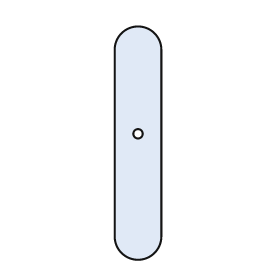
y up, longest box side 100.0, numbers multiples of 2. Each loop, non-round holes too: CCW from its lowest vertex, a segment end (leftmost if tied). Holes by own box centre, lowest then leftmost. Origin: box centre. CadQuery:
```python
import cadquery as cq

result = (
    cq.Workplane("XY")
    .moveTo(-10.0, -40.0)
    .threePointArc((0.0, -50.0), (10.0, -40.0))
    .lineTo(10.0, 40.0)
    .threePointArc((0.0, 50.0), (-10.0, 40.0))
    .close()
    .moveTo(0.0, 4.0)
    .circle(2.0)
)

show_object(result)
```